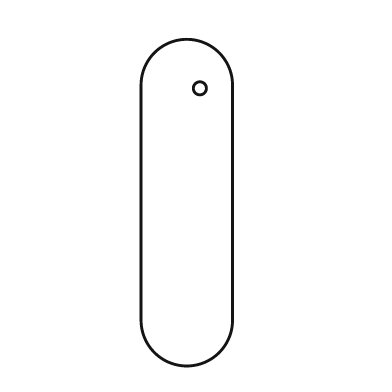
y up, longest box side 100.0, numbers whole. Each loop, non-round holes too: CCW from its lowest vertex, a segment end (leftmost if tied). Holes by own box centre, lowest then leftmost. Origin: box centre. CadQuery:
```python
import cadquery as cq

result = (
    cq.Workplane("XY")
    .moveTo(-14.0, -36.0)
    .threePointArc((0.0, -50.0), (14.0, -36.0))
    .lineTo(14.0, 36.0)
    .threePointArc((0.0, 50.0), (-14.0, 36.0))
    .close()
    .moveTo(4.0, 35.0)
    .circle(2.0)
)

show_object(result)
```